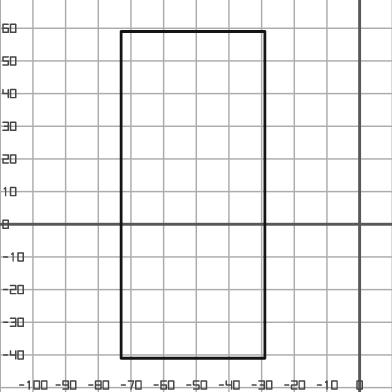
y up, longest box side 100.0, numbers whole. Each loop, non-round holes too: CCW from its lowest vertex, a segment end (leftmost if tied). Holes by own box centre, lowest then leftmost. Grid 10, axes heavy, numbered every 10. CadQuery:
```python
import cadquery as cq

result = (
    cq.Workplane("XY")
    .moveTo(-73.0, -41.0)
    .lineTo(-29.0, -41.0)
    .lineTo(-29.0, 59.0)
    .lineTo(-73.0, 59.0)
    .close()
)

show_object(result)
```